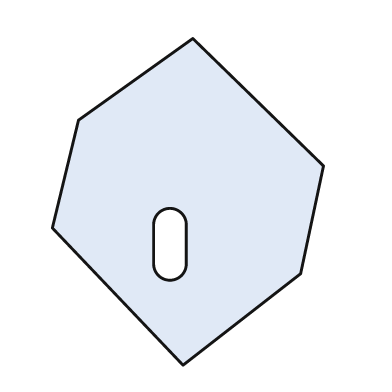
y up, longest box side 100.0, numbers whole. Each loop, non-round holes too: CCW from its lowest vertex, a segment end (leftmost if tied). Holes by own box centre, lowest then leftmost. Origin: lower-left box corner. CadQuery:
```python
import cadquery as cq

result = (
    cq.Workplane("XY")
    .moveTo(40.0, 0.0)
    .lineTo(76.0, 28.0)
    .lineTo(83.0, 61.0)
    .lineTo(43.0, 100.0)
    .lineTo(8.0, 75.0)
    .lineTo(0.0, 42.0)
    .close()
    .moveTo(31.0, 31.0)
    .threePointArc((36.0, 26.0), (41.0, 31.0))
    .lineTo(41.0, 43.0)
    .threePointArc((36.0, 48.0), (31.0, 43.0))
    .close()
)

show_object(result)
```